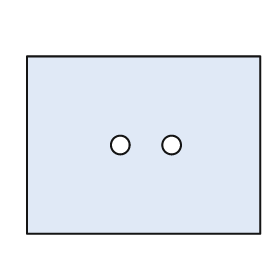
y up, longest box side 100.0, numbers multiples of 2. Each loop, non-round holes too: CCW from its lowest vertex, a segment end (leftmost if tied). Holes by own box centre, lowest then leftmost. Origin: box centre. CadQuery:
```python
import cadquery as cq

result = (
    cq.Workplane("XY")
    .moveTo(-50.0, -38.0)
    .lineTo(50.0, -38.0)
    .lineTo(50.0, 38.0)
    .lineTo(-50.0, 38.0)
    .close()
    .moveTo(-10.0, 0.0)
    .circle(4.0)
    .moveTo(12.0, 0.0)
    .circle(4.0)
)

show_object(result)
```